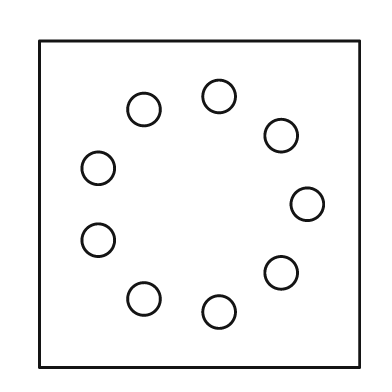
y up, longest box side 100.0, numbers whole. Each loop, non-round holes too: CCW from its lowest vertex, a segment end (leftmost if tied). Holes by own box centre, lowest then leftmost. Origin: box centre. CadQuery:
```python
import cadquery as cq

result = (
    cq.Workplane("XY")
    .moveTo(-49.0, -50.0)
    .lineTo(49.0, -50.0)
    .lineTo(49.0, 50.0)
    .lineTo(-49.0, 50.0)
    .close()
    .moveTo(6.0, -33.0)
    .circle(5.0)
    .moveTo(-17.0, -29.0)
    .circle(5.0)
    .moveTo(25.0, -21.0)
    .circle(5.0)
    .moveTo(-31.0, -11.0)
    .circle(5.0)
    .moveTo(33.0, 0.0)
    .circle(5.0)
    .moveTo(-31.0, 11.0)
    .circle(5.0)
    .moveTo(25.0, 21.0)
    .circle(5.0)
    .moveTo(-17.0, 29.0)
    .circle(5.0)
    .moveTo(6.0, 33.0)
    .circle(5.0)
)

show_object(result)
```